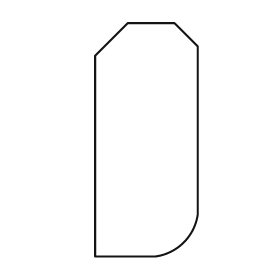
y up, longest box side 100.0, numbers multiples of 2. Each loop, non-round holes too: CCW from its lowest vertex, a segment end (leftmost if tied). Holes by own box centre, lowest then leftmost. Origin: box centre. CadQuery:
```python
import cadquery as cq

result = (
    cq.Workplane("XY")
    .moveTo(-22.0, -50.0)
    .lineTo(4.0, -50.0)
    .threePointArc((16.0, -44.0), (22.0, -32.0))
    .lineTo(22.0, 40.0)
    .lineTo(12.0, 50.0)
    .lineTo(-8.0, 50.0)
    .lineTo(-22.0, 36.0)
    .close()
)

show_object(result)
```